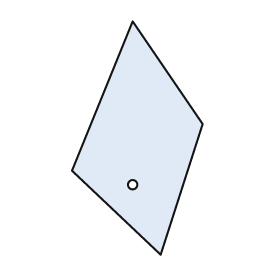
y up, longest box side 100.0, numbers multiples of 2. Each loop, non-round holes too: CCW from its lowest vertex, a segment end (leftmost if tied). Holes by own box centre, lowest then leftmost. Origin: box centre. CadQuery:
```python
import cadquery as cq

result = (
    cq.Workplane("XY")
    .moveTo(10.0, -50.0)
    .lineTo(28.0, 6.0)
    .lineTo(-2.0, 50.0)
    .lineTo(-28.0, -14.0)
    .close()
    .moveTo(-2.0, -20.0)
    .circle(2.0)
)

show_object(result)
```